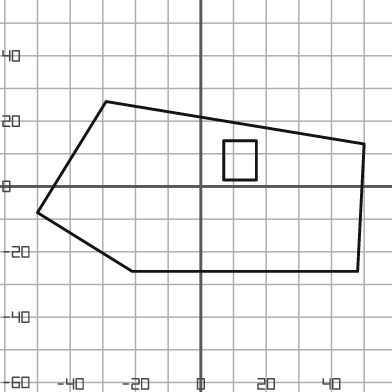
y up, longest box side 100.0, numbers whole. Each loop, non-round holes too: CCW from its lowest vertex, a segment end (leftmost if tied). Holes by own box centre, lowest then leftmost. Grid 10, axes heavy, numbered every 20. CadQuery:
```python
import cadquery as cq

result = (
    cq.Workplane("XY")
    .moveTo(-21.0, -26.0)
    .lineTo(48.0, -26.0)
    .lineTo(50.0, 13.0)
    .lineTo(-29.0, 26.0)
    .lineTo(-50.0, -8.0)
    .close()
    .moveTo(7.0, 2.0)
    .lineTo(17.0, 2.0)
    .lineTo(17.0, 14.0)
    .lineTo(7.0, 14.0)
    .close()
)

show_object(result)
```